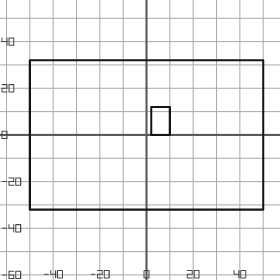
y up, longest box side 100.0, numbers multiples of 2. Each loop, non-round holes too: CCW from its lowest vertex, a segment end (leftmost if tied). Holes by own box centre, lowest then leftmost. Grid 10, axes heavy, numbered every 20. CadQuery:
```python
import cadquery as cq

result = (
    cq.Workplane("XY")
    .moveTo(-50.0, -32.0)
    .lineTo(50.0, -32.0)
    .lineTo(50.0, 32.0)
    .lineTo(-50.0, 32.0)
    .close()
    .moveTo(2.0, 0.0)
    .lineTo(10.0, 0.0)
    .lineTo(10.0, 12.0)
    .lineTo(2.0, 12.0)
    .close()
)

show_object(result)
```